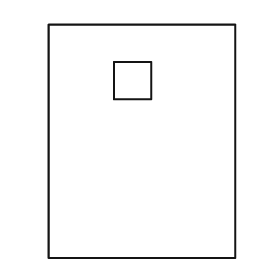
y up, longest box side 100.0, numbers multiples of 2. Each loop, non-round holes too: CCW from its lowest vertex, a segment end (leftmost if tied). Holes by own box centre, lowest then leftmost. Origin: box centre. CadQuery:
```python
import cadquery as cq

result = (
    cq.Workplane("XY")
    .moveTo(-40.0, -50.0)
    .lineTo(40.0, -50.0)
    .lineTo(40.0, 50.0)
    .lineTo(-40.0, 50.0)
    .close()
    .moveTo(-12.0, 18.0)
    .lineTo(4.0, 18.0)
    .lineTo(4.0, 34.0)
    .lineTo(-12.0, 34.0)
    .close()
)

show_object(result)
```